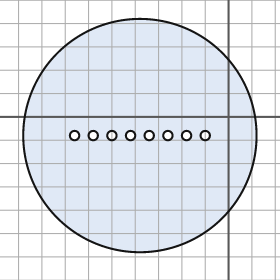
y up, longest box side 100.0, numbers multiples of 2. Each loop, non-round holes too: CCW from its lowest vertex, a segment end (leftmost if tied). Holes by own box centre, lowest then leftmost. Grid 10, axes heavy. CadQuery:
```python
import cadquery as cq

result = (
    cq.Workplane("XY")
    .moveTo(-38.0, -8.0)
    .circle(50.0)
    .moveTo(-66.0, -8.0)
    .circle(2.0)
    .moveTo(-58.0, -8.0)
    .circle(2.0)
    .moveTo(-50.0, -8.0)
    .circle(2.0)
    .moveTo(-42.0, -8.0)
    .circle(2.0)
    .moveTo(-34.0, -8.0)
    .circle(2.0)
    .moveTo(-26.0, -8.0)
    .circle(2.0)
    .moveTo(-18.0, -8.0)
    .circle(2.0)
    .moveTo(-10.0, -8.0)
    .circle(2.0)
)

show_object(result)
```